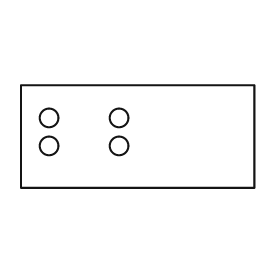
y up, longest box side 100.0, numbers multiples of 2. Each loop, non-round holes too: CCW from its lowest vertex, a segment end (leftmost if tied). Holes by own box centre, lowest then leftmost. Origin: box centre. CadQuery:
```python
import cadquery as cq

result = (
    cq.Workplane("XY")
    .moveTo(-50.0, -22.0)
    .lineTo(50.0, -22.0)
    .lineTo(50.0, 22.0)
    .lineTo(-50.0, 22.0)
    .close()
    .moveTo(-38.0, -4.0)
    .circle(4.0)
    .moveTo(-8.0, -4.0)
    .circle(4.0)
    .moveTo(-38.0, 8.0)
    .circle(4.0)
    .moveTo(-8.0, 8.0)
    .circle(4.0)
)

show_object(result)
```